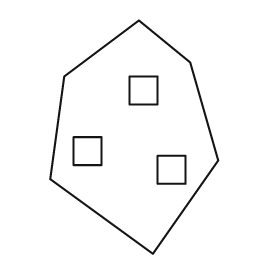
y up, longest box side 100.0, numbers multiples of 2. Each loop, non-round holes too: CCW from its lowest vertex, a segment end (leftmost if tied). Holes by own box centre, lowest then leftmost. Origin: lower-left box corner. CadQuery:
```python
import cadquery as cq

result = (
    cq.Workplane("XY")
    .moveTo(44.0, 0.0)
    .lineTo(72.0, 40.0)
    .lineTo(60.0, 82.0)
    .lineTo(38.0, 100.0)
    .lineTo(6.0, 76.0)
    .lineTo(0.0, 32.0)
    .close()
    .moveTo(46.0, 30.0)
    .lineTo(58.0, 30.0)
    .lineTo(58.0, 42.0)
    .lineTo(46.0, 42.0)
    .close()
    .moveTo(10.0, 38.0)
    .lineTo(22.0, 38.0)
    .lineTo(22.0, 50.0)
    .lineTo(10.0, 50.0)
    .close()
    .moveTo(34.0, 64.0)
    .lineTo(46.0, 64.0)
    .lineTo(46.0, 76.0)
    .lineTo(34.0, 76.0)
    .close()
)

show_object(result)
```